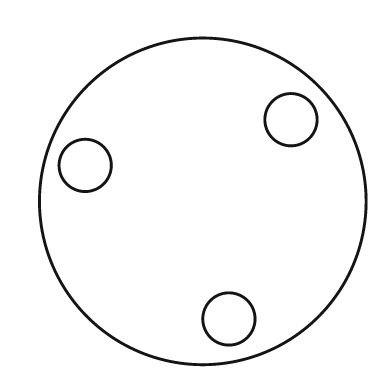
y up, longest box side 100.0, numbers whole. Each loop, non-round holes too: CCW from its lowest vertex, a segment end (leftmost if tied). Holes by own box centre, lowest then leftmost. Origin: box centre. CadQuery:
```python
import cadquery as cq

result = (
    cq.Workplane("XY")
    .moveTo(0.0, 0.0)
    .circle(50.0)
    .moveTo(8.0, -36.0)
    .circle(8.0)
    .moveTo(-36.0, 11.0)
    .circle(8.0)
    .moveTo(27.0, 25.0)
    .circle(8.0)
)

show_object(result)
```